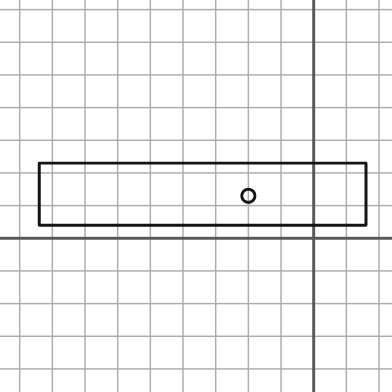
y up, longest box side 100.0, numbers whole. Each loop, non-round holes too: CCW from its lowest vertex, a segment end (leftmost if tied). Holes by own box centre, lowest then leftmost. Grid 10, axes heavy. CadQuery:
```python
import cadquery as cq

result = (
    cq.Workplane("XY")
    .moveTo(-84.0, 4.0)
    .lineTo(16.0, 4.0)
    .lineTo(16.0, 23.0)
    .lineTo(-84.0, 23.0)
    .close()
    .moveTo(-20.0, 13.0)
    .circle(2.0)
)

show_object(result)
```